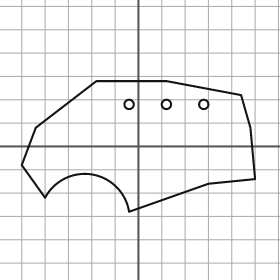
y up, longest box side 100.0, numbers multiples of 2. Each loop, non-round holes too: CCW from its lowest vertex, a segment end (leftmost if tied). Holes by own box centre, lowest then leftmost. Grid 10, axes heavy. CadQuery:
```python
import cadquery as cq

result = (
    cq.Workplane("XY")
    .moveTo(-4.0, -28.0)
    .lineTo(30.0, -16.0)
    .lineTo(50.0, -14.0)
    .lineTo(48.0, 8.0)
    .lineTo(44.0, 22.0)
    .lineTo(12.0, 28.0)
    .lineTo(-18.0, 28.0)
    .lineTo(-44.0, 8.0)
    .lineTo(-50.0, -8.0)
    .lineTo(-40.0, -22.0)
    .threePointArc((-20.0, -12.0), (-4.0, -28.0))
    .close()
    .moveTo(-4.0, 18.0)
    .circle(2.0)
    .moveTo(12.0, 18.0)
    .circle(2.0)
    .moveTo(28.0, 18.0)
    .circle(2.0)
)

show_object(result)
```